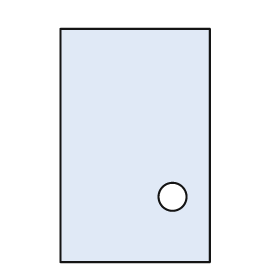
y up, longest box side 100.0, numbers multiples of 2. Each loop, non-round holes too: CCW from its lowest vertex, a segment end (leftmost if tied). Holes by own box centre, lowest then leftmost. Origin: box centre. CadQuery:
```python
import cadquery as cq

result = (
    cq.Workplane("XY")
    .moveTo(-32.0, -50.0)
    .lineTo(32.0, -50.0)
    .lineTo(32.0, 50.0)
    .lineTo(-32.0, 50.0)
    .close()
    .moveTo(16.0, -22.0)
    .circle(6.0)
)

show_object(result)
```